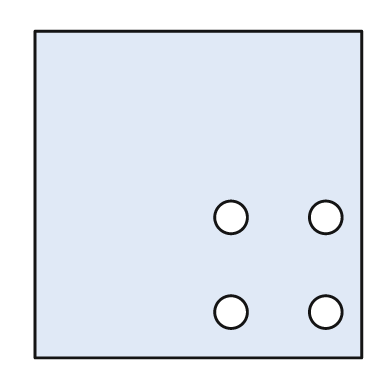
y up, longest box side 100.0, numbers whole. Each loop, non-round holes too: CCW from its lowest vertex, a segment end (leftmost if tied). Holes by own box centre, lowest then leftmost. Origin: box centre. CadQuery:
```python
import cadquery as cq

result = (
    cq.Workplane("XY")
    .moveTo(-50.0, -50.0)
    .lineTo(50.0, -50.0)
    .lineTo(50.0, 50.0)
    .lineTo(-50.0, 50.0)
    .close()
    .moveTo(10.0, -36.0)
    .circle(5.0)
    .moveTo(39.0, -36.0)
    .circle(5.0)
    .moveTo(10.0, -7.0)
    .circle(5.0)
    .moveTo(39.0, -7.0)
    .circle(5.0)
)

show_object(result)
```